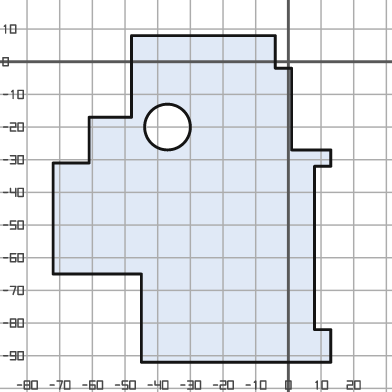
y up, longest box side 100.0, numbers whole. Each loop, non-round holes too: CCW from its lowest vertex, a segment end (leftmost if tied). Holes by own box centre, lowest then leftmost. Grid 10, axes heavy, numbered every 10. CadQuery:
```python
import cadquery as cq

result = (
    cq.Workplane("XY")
    .moveTo(-45.0, -92.0)
    .lineTo(13.0, -92.0)
    .lineTo(13.0, -82.0)
    .lineTo(8.0, -82.0)
    .lineTo(8.0, -32.0)
    .lineTo(13.0, -32.0)
    .lineTo(13.0, -27.0)
    .lineTo(1.0, -27.0)
    .lineTo(1.0, -2.0)
    .lineTo(-4.0, -2.0)
    .lineTo(-4.0, 8.0)
    .lineTo(-48.0, 8.0)
    .lineTo(-48.0, -17.0)
    .lineTo(-61.0, -17.0)
    .lineTo(-61.0, -31.0)
    .lineTo(-72.0, -31.0)
    .lineTo(-72.0, -65.0)
    .lineTo(-45.0, -65.0)
    .close()
    .moveTo(-37.0, -20.0)
    .circle(7.0)
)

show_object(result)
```